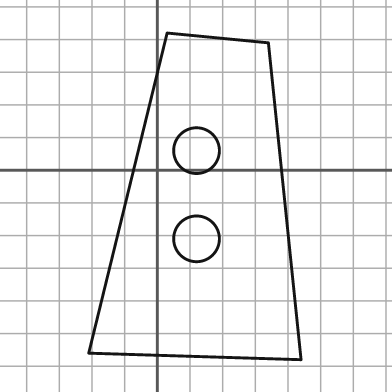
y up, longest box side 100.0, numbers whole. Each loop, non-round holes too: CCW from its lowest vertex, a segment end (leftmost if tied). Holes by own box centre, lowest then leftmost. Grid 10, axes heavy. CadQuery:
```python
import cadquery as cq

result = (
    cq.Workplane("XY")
    .moveTo(44.0, -58.0)
    .lineTo(34.0, 39.0)
    .lineTo(3.0, 42.0)
    .lineTo(-21.0, -56.0)
    .close()
    .moveTo(12.0, -21.0)
    .circle(7.0)
    .moveTo(12.0, 6.0)
    .circle(7.0)
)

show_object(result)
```